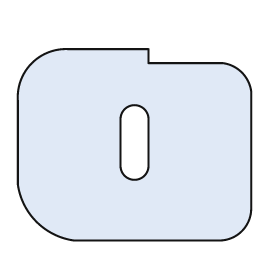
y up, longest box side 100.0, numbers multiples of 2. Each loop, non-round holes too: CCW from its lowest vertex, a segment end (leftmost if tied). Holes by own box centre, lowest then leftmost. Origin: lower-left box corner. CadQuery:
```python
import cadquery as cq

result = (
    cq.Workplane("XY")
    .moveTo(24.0, 0.0)
    .lineTo(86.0, 0.0)
    .threePointArc((96.0, 4.0), (100.0, 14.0))
    .lineTo(100.0, 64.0)
    .threePointArc((96.0, 72.0), (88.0, 76.0))
    .lineTo(56.0, 76.0)
    .lineTo(56.0, 82.0)
    .lineTo(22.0, 82.0)
    .threePointArc((6.0, 76.0), (0.0, 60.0))
    .lineTo(0.0, 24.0)
    .threePointArc((8.0, 8.0), (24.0, 0.0))
    .close()
    .moveTo(44.0, 32.0)
    .threePointArc((50.0, 26.0), (56.0, 32.0))
    .lineTo(56.0, 52.0)
    .threePointArc((50.0, 58.0), (44.0, 52.0))
    .close()
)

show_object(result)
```